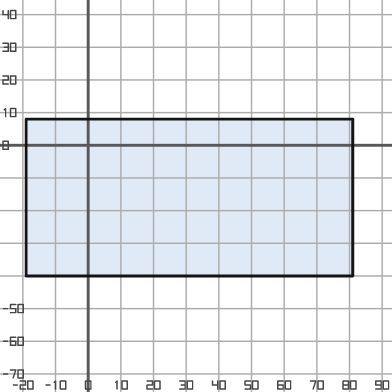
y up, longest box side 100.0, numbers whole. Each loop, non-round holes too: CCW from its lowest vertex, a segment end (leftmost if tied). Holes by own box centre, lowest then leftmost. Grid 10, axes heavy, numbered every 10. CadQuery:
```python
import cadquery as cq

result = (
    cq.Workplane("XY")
    .moveTo(-19.0, -40.0)
    .lineTo(81.0, -40.0)
    .lineTo(81.0, 8.0)
    .lineTo(-19.0, 8.0)
    .close()
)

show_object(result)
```